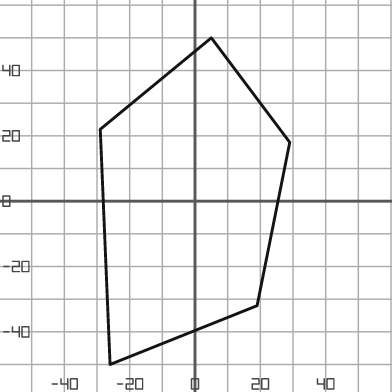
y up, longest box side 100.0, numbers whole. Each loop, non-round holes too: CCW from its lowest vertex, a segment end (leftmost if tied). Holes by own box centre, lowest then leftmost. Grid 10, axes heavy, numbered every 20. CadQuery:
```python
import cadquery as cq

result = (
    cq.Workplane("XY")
    .moveTo(-26.0, -50.0)
    .lineTo(19.0, -32.0)
    .lineTo(29.0, 18.0)
    .lineTo(5.0, 50.0)
    .lineTo(-29.0, 22.0)
    .close()
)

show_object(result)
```